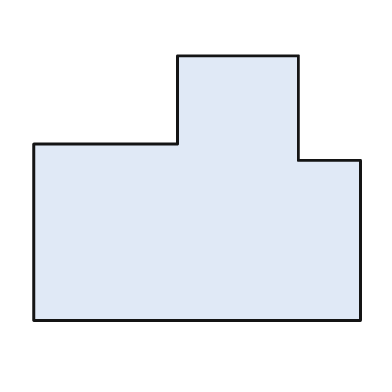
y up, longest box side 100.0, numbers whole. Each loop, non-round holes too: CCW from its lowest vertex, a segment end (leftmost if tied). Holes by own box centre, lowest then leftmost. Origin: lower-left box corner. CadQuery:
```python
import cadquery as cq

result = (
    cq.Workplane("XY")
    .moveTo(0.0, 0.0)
    .lineTo(100.0, 0.0)
    .lineTo(100.0, 49.0)
    .lineTo(81.0, 49.0)
    .lineTo(81.0, 81.0)
    .lineTo(44.0, 81.0)
    .lineTo(44.0, 54.0)
    .lineTo(0.0, 54.0)
    .close()
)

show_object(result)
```